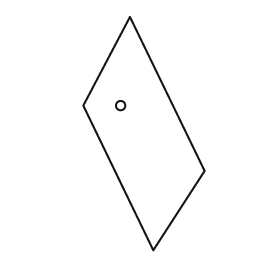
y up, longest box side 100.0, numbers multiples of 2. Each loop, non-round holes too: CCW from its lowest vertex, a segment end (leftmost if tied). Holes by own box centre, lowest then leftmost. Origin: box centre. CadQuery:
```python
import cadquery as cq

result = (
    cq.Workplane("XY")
    .moveTo(4.0, -50.0)
    .lineTo(26.0, -16.0)
    .lineTo(-6.0, 50.0)
    .lineTo(-26.0, 12.0)
    .close()
    .moveTo(-10.0, 12.0)
    .circle(2.0)
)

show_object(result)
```